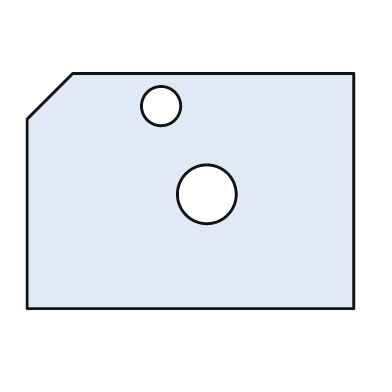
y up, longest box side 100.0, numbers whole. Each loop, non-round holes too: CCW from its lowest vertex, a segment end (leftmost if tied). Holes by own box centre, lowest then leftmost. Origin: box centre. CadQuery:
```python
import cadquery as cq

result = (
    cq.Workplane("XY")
    .moveTo(-50.0, -36.0)
    .lineTo(50.0, -36.0)
    .lineTo(50.0, 36.0)
    .lineTo(-36.0, 36.0)
    .lineTo(-50.0, 22.0)
    .close()
    .moveTo(5.0, -1.0)
    .circle(9.0)
    .moveTo(-9.0, 26.0)
    .circle(6.0)
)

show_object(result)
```